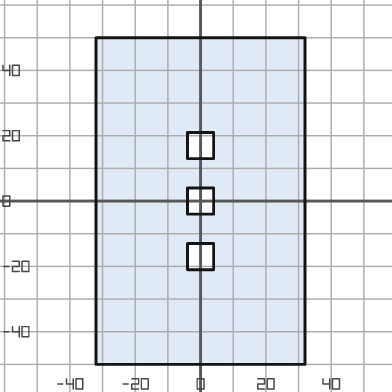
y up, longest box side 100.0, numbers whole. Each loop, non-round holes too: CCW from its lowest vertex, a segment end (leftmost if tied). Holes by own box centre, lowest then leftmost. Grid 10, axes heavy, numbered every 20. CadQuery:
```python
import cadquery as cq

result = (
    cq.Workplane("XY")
    .moveTo(-32.0, -50.0)
    .lineTo(32.0, -50.0)
    .lineTo(32.0, 50.0)
    .lineTo(-32.0, 50.0)
    .close()
    .moveTo(-4.0, -21.0)
    .lineTo(4.0, -21.0)
    .lineTo(4.0, -13.0)
    .lineTo(-4.0, -13.0)
    .close()
    .moveTo(-4.0, -4.0)
    .lineTo(4.0, -4.0)
    .lineTo(4.0, 4.0)
    .lineTo(-4.0, 4.0)
    .close()
    .moveTo(-4.0, 13.0)
    .lineTo(4.0, 13.0)
    .lineTo(4.0, 21.0)
    .lineTo(-4.0, 21.0)
    .close()
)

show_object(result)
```